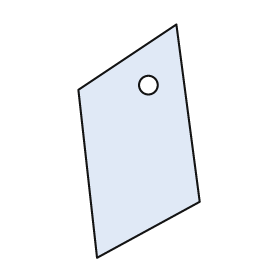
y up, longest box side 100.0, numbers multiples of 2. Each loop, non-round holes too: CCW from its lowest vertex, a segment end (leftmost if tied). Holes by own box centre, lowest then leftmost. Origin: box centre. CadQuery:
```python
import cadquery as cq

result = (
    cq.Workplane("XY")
    .moveTo(-18.0, -50.0)
    .lineTo(26.0, -26.0)
    .lineTo(16.0, 50.0)
    .lineTo(-26.0, 22.0)
    .close()
    .moveTo(4.0, 24.0)
    .circle(4.0)
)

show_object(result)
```